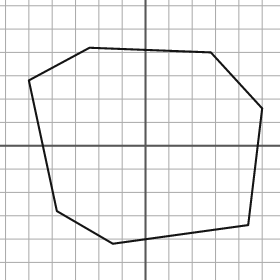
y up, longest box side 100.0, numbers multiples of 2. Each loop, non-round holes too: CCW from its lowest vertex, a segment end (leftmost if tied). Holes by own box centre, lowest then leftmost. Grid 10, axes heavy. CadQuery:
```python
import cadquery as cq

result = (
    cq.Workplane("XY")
    .moveTo(-14.0, -42.0)
    .lineTo(44.0, -34.0)
    .lineTo(50.0, 16.0)
    .lineTo(28.0, 40.0)
    .lineTo(-24.0, 42.0)
    .lineTo(-50.0, 28.0)
    .lineTo(-38.0, -28.0)
    .close()
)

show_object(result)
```